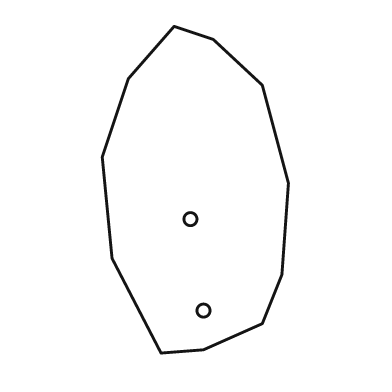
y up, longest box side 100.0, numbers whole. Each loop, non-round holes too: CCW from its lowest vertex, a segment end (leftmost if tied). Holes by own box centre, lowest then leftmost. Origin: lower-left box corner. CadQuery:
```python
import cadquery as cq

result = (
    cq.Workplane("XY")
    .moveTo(18.0, 0.0)
    .lineTo(31.0, 1.0)
    .lineTo(49.0, 9.0)
    .lineTo(55.0, 24.0)
    .lineTo(57.0, 52.0)
    .lineTo(49.0, 82.0)
    .lineTo(34.0, 96.0)
    .lineTo(22.0, 100.0)
    .lineTo(8.0, 84.0)
    .lineTo(0.0, 60.0)
    .lineTo(3.0, 29.0)
    .close()
    .moveTo(31.0, 13.0)
    .circle(2.0)
    .moveTo(27.0, 41.0)
    .circle(2.0)
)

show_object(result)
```